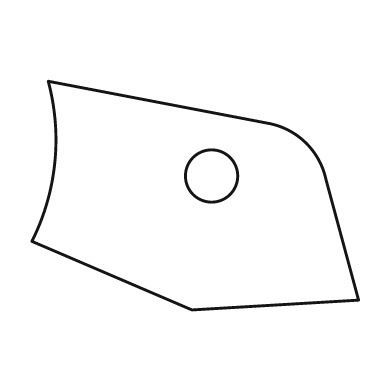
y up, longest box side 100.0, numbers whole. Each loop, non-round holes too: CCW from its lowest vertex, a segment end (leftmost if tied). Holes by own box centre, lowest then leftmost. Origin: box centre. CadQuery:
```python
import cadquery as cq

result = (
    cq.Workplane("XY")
    .moveTo(-1.0, -35.0)
    .lineTo(50.0, -32.0)
    .lineTo(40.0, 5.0)
    .threePointArc((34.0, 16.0), (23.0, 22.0))
    .lineTo(-45.0, 35.0)
    .threePointArc((-43.0, 10.0), (-50.0, -14.0))
    .close()
    .moveTo(5.0, 6.0)
    .circle(8.0)
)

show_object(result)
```